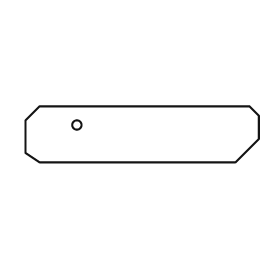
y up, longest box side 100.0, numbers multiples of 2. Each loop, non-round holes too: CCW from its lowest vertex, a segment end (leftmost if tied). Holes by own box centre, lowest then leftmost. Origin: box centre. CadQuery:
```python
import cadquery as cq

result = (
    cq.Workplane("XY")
    .moveTo(-44.0, -12.0)
    .lineTo(40.0, -12.0)
    .lineTo(50.0, -2.0)
    .lineTo(50.0, 8.0)
    .lineTo(46.0, 12.0)
    .lineTo(-44.0, 12.0)
    .lineTo(-50.0, 6.0)
    .lineTo(-50.0, -8.0)
    .close()
    .moveTo(-28.0, 4.0)
    .circle(2.0)
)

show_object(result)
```